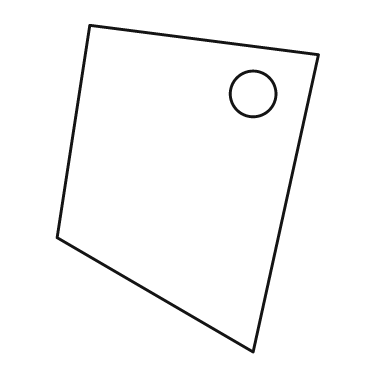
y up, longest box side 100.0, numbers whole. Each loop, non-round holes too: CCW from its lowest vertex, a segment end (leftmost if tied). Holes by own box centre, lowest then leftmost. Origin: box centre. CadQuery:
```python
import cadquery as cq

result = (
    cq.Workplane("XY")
    .moveTo(20.0, -50.0)
    .lineTo(40.0, 41.0)
    .lineTo(-30.0, 50.0)
    .lineTo(-40.0, -15.0)
    .close()
    .moveTo(20.0, 29.0)
    .circle(7.0)
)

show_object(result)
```